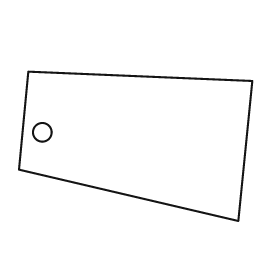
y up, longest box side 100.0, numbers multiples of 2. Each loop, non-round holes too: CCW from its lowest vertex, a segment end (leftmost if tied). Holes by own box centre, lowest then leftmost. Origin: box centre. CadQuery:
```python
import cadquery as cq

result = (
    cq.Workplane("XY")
    .moveTo(44.0, -32.0)
    .lineTo(50.0, 28.0)
    .lineTo(-46.0, 32.0)
    .lineTo(-50.0, -10.0)
    .close()
    .moveTo(-40.0, 6.0)
    .circle(4.0)
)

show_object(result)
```